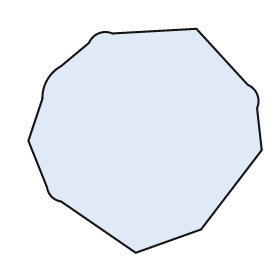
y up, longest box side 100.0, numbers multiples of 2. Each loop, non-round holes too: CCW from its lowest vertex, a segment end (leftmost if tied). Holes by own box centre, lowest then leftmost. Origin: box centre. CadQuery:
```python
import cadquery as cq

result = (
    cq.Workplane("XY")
    .moveTo(-4.0, -48.0)
    .lineTo(24.0, -38.0)
    .lineTo(50.0, -4.0)
    .lineTo(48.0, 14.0)
    .threePointArc((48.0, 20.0), (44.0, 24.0))
    .lineTo(22.0, 48.0)
    .lineTo(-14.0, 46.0)
    .threePointArc((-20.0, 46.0), (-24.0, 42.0))
    .lineTo(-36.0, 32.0)
    .threePointArc((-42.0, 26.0), (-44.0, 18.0))
    .lineTo(-50.0, 0.0)
    .lineTo(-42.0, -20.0)
    .threePointArc((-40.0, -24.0), (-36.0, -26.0))
    .close()
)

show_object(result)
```